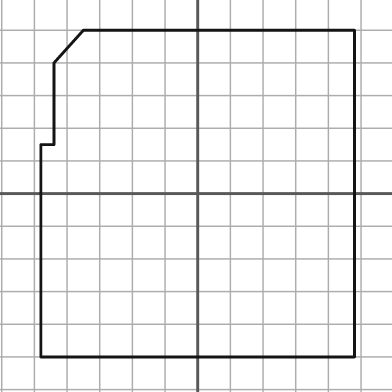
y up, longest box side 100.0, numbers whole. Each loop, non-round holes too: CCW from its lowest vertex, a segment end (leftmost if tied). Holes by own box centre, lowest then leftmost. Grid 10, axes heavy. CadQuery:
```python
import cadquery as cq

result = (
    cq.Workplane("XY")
    .moveTo(-48.0, -50.0)
    .lineTo(48.0, -50.0)
    .lineTo(48.0, 50.0)
    .lineTo(-35.0, 50.0)
    .lineTo(-44.0, 40.0)
    .lineTo(-44.0, 15.0)
    .lineTo(-48.0, 15.0)
    .close()
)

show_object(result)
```